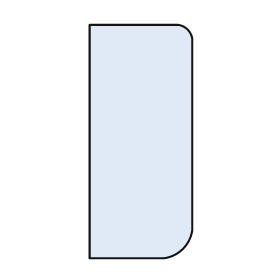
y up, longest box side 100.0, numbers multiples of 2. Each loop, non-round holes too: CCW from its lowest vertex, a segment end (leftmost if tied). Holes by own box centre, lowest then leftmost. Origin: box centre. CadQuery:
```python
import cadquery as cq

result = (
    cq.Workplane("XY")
    .moveTo(-22.0, -50.0)
    .lineTo(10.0, -50.0)
    .threePointArc((18.0, -46.0), (22.0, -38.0))
    .lineTo(22.0, 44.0)
    .threePointArc((20.0, 48.0), (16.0, 50.0))
    .lineTo(-22.0, 50.0)
    .close()
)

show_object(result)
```